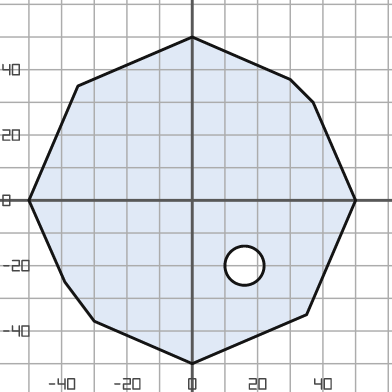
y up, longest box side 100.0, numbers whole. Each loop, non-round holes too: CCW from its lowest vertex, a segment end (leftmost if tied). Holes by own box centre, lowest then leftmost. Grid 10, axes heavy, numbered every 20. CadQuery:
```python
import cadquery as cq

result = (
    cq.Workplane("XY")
    .moveTo(0.0, -50.0)
    .lineTo(35.0, -35.0)
    .lineTo(50.0, 0.0)
    .lineTo(37.0, 30.0)
    .lineTo(30.0, 37.0)
    .lineTo(0.0, 50.0)
    .lineTo(-35.0, 35.0)
    .lineTo(-50.0, 0.0)
    .lineTo(-39.0, -25.0)
    .lineTo(-30.0, -37.0)
    .close()
    .moveTo(16.0, -20.0)
    .circle(6.0)
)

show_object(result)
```